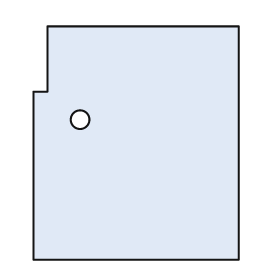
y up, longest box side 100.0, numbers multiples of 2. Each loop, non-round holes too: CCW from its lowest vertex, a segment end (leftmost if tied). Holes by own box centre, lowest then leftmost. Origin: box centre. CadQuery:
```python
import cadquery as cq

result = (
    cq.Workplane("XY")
    .moveTo(-44.0, -50.0)
    .lineTo(44.0, -50.0)
    .lineTo(44.0, 50.0)
    .lineTo(-38.0, 50.0)
    .lineTo(-38.0, 22.0)
    .lineTo(-44.0, 22.0)
    .close()
    .moveTo(-24.0, 10.0)
    .circle(4.0)
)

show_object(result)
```